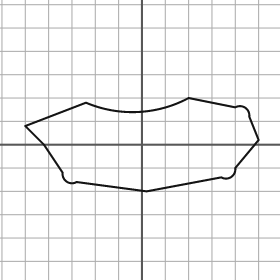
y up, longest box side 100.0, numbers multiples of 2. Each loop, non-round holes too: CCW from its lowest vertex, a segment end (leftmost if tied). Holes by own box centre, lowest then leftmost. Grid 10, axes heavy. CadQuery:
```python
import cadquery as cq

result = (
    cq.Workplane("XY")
    .moveTo(2.0, -20.0)
    .lineTo(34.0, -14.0)
    .threePointArc((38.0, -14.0), (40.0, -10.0))
    .lineTo(50.0, 2.0)
    .lineTo(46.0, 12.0)
    .threePointArc((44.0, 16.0), (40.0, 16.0))
    .lineTo(20.0, 20.0)
    .threePointArc((-2.0, 14.0), (-24.0, 18.0))
    .lineTo(-50.0, 8.0)
    .lineTo(-42.0, 0.0)
    .lineTo(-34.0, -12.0)
    .threePointArc((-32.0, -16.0), (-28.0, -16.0))
    .close()
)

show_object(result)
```